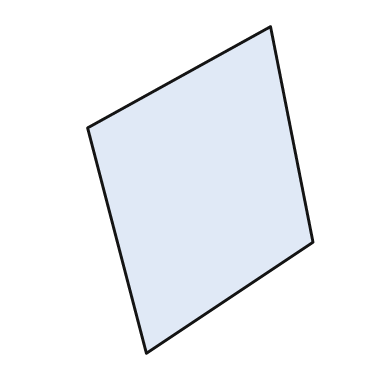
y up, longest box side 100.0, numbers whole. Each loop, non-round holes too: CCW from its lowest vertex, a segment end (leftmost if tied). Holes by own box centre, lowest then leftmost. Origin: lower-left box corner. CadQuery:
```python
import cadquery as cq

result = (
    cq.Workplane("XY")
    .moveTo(18.0, 0.0)
    .lineTo(69.0, 34.0)
    .lineTo(56.0, 100.0)
    .lineTo(0.0, 69.0)
    .close()
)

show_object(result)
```